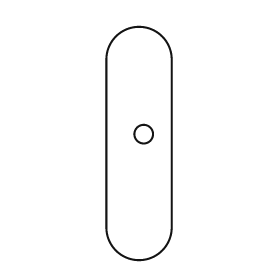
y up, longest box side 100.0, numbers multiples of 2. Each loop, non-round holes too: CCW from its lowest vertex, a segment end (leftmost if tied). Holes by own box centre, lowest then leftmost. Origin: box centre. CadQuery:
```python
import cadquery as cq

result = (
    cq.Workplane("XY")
    .moveTo(-14.0, -36.0)
    .threePointArc((0.0, -50.0), (14.0, -36.0))
    .lineTo(14.0, 36.0)
    .threePointArc((0.0, 50.0), (-14.0, 36.0))
    .close()
    .moveTo(2.0, 4.0)
    .circle(4.0)
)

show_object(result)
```